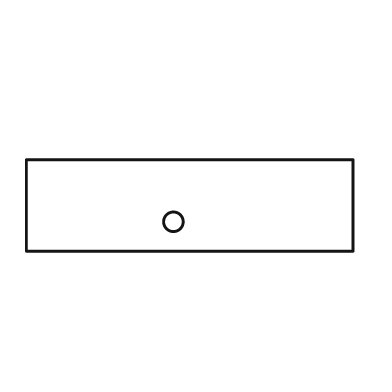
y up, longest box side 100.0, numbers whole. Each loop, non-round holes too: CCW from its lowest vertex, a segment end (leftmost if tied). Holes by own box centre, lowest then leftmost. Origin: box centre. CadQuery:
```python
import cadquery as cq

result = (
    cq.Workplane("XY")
    .moveTo(-50.0, -14.0)
    .lineTo(50.0, -14.0)
    .lineTo(50.0, 14.0)
    .lineTo(-50.0, 14.0)
    .close()
    .moveTo(-5.0, -5.0)
    .circle(3.0)
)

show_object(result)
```